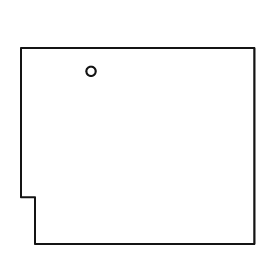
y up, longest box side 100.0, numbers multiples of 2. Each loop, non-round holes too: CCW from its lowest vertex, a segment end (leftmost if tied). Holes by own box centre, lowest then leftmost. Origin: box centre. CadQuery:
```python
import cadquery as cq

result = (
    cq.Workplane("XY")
    .moveTo(-44.0, -42.0)
    .lineTo(50.0, -42.0)
    .lineTo(50.0, 42.0)
    .lineTo(-50.0, 42.0)
    .lineTo(-50.0, -22.0)
    .lineTo(-44.0, -22.0)
    .close()
    .moveTo(-20.0, 32.0)
    .circle(2.0)
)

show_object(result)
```